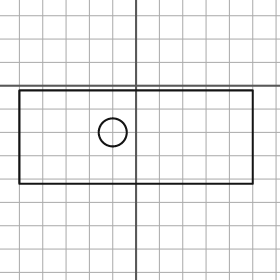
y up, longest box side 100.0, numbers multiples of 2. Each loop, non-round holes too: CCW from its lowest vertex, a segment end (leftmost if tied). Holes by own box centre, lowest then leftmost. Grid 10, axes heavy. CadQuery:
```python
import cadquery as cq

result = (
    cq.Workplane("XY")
    .moveTo(-50.0, -42.0)
    .lineTo(50.0, -42.0)
    .lineTo(50.0, -2.0)
    .lineTo(-50.0, -2.0)
    .close()
    .moveTo(-10.0, -20.0)
    .circle(6.0)
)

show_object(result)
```